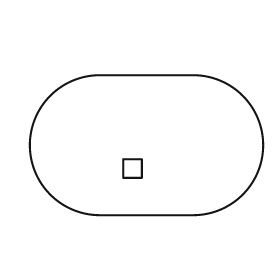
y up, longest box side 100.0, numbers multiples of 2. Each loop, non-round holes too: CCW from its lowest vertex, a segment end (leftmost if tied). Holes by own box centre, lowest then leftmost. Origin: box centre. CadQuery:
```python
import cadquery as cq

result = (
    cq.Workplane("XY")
    .moveTo(-20.0, -30.0)
    .lineTo(20.0, -30.0)
    .threePointArc((50.0, 0.0), (20.0, 30.0))
    .lineTo(-20.0, 30.0)
    .threePointArc((-50.0, 0.0), (-20.0, -30.0))
    .close()
    .moveTo(-10.0, -14.0)
    .lineTo(-2.0, -14.0)
    .lineTo(-2.0, -6.0)
    .lineTo(-10.0, -6.0)
    .close()
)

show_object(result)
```